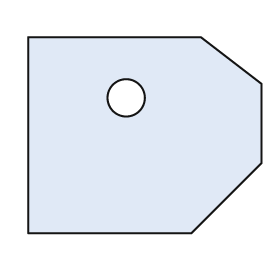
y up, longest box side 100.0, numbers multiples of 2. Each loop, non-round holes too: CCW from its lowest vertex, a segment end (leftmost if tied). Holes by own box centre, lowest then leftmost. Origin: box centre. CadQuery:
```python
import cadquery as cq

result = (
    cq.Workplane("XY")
    .moveTo(-50.0, -42.0)
    .lineTo(20.0, -42.0)
    .lineTo(50.0, -12.0)
    .lineTo(50.0, 22.0)
    .lineTo(24.0, 42.0)
    .lineTo(-50.0, 42.0)
    .close()
    .moveTo(-8.0, 16.0)
    .circle(8.0)
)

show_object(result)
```